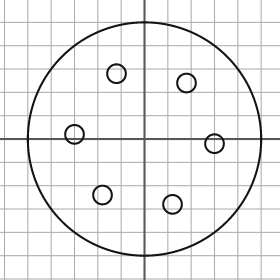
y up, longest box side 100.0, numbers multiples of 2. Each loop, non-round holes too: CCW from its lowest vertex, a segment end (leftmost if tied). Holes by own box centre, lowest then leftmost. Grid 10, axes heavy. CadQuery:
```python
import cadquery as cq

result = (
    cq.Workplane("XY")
    .moveTo(0.0, 0.0)
    .circle(50.0)
    .moveTo(12.0, -28.0)
    .circle(4.0)
    .moveTo(-18.0, -24.0)
    .circle(4.0)
    .moveTo(30.0, -2.0)
    .circle(4.0)
    .moveTo(-30.0, 2.0)
    .circle(4.0)
    .moveTo(18.0, 24.0)
    .circle(4.0)
    .moveTo(-12.0, 28.0)
    .circle(4.0)
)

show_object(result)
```